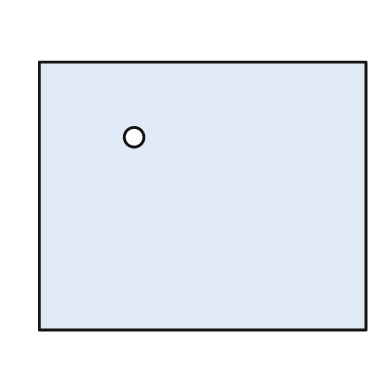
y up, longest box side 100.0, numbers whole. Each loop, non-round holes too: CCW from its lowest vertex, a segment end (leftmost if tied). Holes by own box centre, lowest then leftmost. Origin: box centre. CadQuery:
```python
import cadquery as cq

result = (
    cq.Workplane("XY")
    .moveTo(-50.0, -41.0)
    .lineTo(50.0, -41.0)
    .lineTo(50.0, 41.0)
    .lineTo(-50.0, 41.0)
    .close()
    .moveTo(-21.0, 18.0)
    .circle(3.0)
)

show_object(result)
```